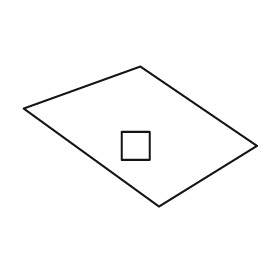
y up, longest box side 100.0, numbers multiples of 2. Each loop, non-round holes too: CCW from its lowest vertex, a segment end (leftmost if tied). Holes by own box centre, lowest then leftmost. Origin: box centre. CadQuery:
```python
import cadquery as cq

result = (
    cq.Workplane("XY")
    .moveTo(8.0, -30.0)
    .lineTo(50.0, -4.0)
    .lineTo(0.0, 30.0)
    .lineTo(-50.0, 12.0)
    .close()
    .moveTo(-8.0, -10.0)
    .lineTo(4.0, -10.0)
    .lineTo(4.0, 2.0)
    .lineTo(-8.0, 2.0)
    .close()
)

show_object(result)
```